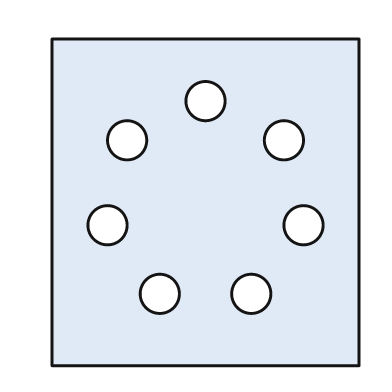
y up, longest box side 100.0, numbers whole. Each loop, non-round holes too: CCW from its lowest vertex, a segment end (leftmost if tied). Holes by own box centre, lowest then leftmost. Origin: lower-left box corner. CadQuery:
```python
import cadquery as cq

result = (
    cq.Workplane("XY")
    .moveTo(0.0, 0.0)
    .lineTo(94.0, 0.0)
    .lineTo(94.0, 100.0)
    .lineTo(0.0, 100.0)
    .close()
    .moveTo(33.0, 22.0)
    .circle(6.0)
    .moveTo(61.0, 22.0)
    .circle(6.0)
    .moveTo(17.0, 43.0)
    .circle(6.0)
    .moveTo(77.0, 43.0)
    .circle(6.0)
    .moveTo(23.0, 69.0)
    .circle(6.0)
    .moveTo(71.0, 69.0)
    .circle(6.0)
    .moveTo(47.0, 81.0)
    .circle(6.0)
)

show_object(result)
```